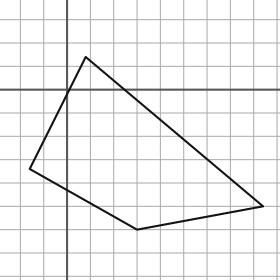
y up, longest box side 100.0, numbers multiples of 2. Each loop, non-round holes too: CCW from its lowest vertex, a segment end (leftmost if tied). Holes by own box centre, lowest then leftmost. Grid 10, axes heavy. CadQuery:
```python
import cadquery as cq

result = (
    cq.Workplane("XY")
    .moveTo(30.0, -60.0)
    .lineTo(84.0, -50.0)
    .lineTo(8.0, 14.0)
    .lineTo(-16.0, -34.0)
    .close()
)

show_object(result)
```